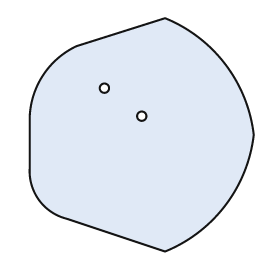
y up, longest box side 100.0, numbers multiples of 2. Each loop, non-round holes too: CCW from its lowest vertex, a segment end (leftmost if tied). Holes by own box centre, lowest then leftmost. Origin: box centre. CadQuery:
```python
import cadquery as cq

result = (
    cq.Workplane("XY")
    .moveTo(10.0, -50.0)
    .threePointArc((36.0, -30.0), (48.0, 0.0))
    .threePointArc((36.0, 30.0), (10.0, 50.0))
    .lineTo(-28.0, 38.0)
    .threePointArc((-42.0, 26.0), (-48.0, 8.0))
    .lineTo(-48.0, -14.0)
    .threePointArc((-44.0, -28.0), (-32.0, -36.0))
    .close()
    .moveTo(0.0, 8.0)
    .circle(2.0)
    .moveTo(-16.0, 20.0)
    .circle(2.0)
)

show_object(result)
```